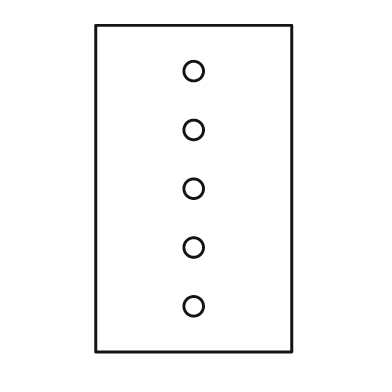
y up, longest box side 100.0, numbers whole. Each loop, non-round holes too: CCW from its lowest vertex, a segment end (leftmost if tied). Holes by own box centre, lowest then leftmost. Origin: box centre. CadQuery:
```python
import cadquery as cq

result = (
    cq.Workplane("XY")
    .moveTo(-30.0, -50.0)
    .lineTo(30.0, -50.0)
    .lineTo(30.0, 50.0)
    .lineTo(-30.0, 50.0)
    .close()
    .moveTo(0.0, -36.0)
    .circle(3.0)
    .moveTo(0.0, -18.0)
    .circle(3.0)
    .moveTo(0.0, 0.0)
    .circle(3.0)
    .moveTo(0.0, 18.0)
    .circle(3.0)
    .moveTo(0.0, 36.0)
    .circle(3.0)
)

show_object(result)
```